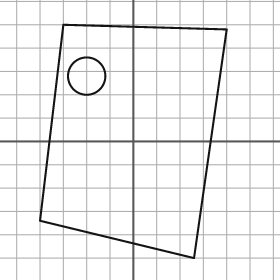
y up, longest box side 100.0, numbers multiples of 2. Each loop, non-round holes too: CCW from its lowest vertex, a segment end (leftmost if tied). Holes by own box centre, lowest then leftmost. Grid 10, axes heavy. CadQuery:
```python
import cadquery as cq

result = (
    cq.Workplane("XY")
    .moveTo(26.0, -50.0)
    .lineTo(40.0, 48.0)
    .lineTo(-30.0, 50.0)
    .lineTo(-40.0, -34.0)
    .close()
    .moveTo(-20.0, 28.0)
    .circle(8.0)
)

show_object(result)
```